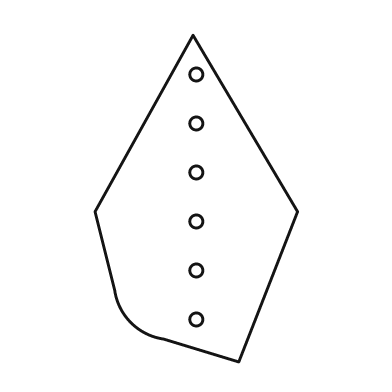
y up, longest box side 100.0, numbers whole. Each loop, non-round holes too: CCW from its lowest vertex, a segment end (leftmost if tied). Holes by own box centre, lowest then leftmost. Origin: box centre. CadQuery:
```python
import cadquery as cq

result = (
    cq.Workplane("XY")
    .moveTo(13.0, -50.0)
    .lineTo(31.0, -4.0)
    .lineTo(-1.0, 50.0)
    .lineTo(-31.0, -4.0)
    .lineTo(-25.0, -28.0)
    .threePointArc((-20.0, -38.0), (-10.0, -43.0))
    .close()
    .moveTo(0.0, -37.0)
    .circle(2.0)
    .moveTo(0.0, -22.0)
    .circle(2.0)
    .moveTo(0.0, -7.0)
    .circle(2.0)
    .moveTo(0.0, 8.0)
    .circle(2.0)
    .moveTo(0.0, 23.0)
    .circle(2.0)
    .moveTo(0.0, 38.0)
    .circle(2.0)
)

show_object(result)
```